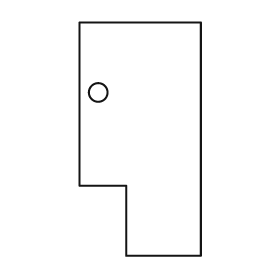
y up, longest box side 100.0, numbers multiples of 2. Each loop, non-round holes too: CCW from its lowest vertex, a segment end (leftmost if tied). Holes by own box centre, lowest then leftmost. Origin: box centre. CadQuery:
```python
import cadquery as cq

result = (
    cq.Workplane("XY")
    .moveTo(-6.0, -50.0)
    .lineTo(26.0, -50.0)
    .lineTo(26.0, 50.0)
    .lineTo(-26.0, 50.0)
    .lineTo(-26.0, -20.0)
    .lineTo(-6.0, -20.0)
    .close()
    .moveTo(-18.0, 20.0)
    .circle(4.0)
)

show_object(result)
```